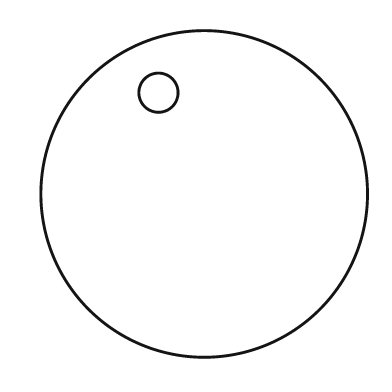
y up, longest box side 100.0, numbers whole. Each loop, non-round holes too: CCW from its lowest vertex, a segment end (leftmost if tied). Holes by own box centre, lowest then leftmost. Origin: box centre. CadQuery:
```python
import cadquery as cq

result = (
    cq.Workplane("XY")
    .moveTo(0.0, 0.0)
    .circle(50.0)
    .moveTo(-14.0, 31.0)
    .circle(6.0)
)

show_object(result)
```